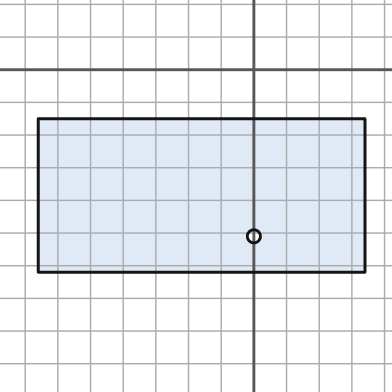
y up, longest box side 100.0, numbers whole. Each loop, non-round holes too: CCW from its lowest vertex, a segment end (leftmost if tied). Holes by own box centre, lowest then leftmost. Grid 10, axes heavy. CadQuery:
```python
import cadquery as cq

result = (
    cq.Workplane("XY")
    .moveTo(-66.0, -62.0)
    .lineTo(34.0, -62.0)
    .lineTo(34.0, -15.0)
    .lineTo(-66.0, -15.0)
    .close()
    .moveTo(0.0, -51.0)
    .circle(2.0)
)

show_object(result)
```